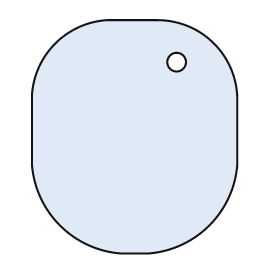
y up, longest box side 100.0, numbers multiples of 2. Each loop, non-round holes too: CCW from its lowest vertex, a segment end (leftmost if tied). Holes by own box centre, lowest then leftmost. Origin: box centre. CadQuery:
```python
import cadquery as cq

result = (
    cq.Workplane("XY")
    .moveTo(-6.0, -50.0)
    .lineTo(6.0, -50.0)
    .threePointArc((32.0, -38.0), (44.0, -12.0))
    .lineTo(44.0, 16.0)
    .threePointArc((34.0, 40.0), (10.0, 50.0))
    .lineTo(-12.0, 50.0)
    .threePointArc((-34.0, 40.0), (-44.0, 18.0))
    .lineTo(-44.0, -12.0)
    .threePointArc((-32.0, -38.0), (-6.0, -50.0))
    .close()
    .moveTo(18.0, 32.0)
    .circle(4.0)
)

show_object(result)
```